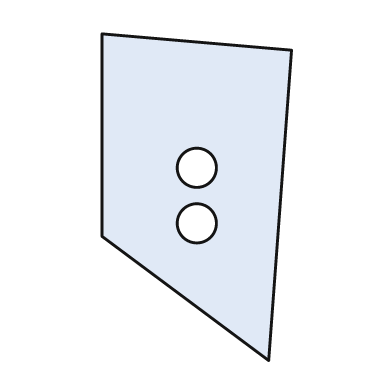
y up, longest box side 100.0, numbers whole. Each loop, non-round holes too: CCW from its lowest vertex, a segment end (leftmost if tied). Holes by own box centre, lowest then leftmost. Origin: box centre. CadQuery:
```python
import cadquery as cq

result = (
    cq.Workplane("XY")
    .moveTo(22.0, -50.0)
    .lineTo(29.0, 45.0)
    .lineTo(-29.0, 50.0)
    .lineTo(-29.0, -12.0)
    .close()
    .moveTo(0.0, -8.0)
    .circle(6.0)
    .moveTo(0.0, 9.0)
    .circle(6.0)
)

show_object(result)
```